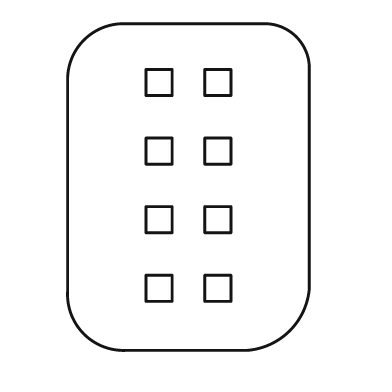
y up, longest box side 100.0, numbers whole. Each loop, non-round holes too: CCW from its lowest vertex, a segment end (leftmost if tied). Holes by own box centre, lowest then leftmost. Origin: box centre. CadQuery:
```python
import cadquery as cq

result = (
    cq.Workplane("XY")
    .moveTo(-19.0, -50.0)
    .lineTo(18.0, -50.0)
    .threePointArc((31.0, -44.0), (37.0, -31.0))
    .lineTo(37.0, 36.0)
    .threePointArc((33.0, 46.0), (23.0, 50.0))
    .lineTo(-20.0, 50.0)
    .threePointArc((-32.0, 45.0), (-37.0, 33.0))
    .lineTo(-37.0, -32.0)
    .threePointArc((-32.0, -45.0), (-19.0, -50.0))
    .close()
    .moveTo(-13.0, -35.0)
    .lineTo(-5.0, -35.0)
    .lineTo(-5.0, -27.0)
    .lineTo(-13.0, -27.0)
    .close()
    .moveTo(5.0, -35.0)
    .lineTo(13.0, -35.0)
    .lineTo(13.0, -27.0)
    .lineTo(5.0, -27.0)
    .close()
    .moveTo(-13.0, -14.0)
    .lineTo(-5.0, -14.0)
    .lineTo(-5.0, -6.0)
    .lineTo(-13.0, -6.0)
    .close()
    .moveTo(5.0, -14.0)
    .lineTo(13.0, -14.0)
    .lineTo(13.0, -6.0)
    .lineTo(5.0, -6.0)
    .close()
    .moveTo(-13.0, 7.0)
    .lineTo(-5.0, 7.0)
    .lineTo(-5.0, 15.0)
    .lineTo(-13.0, 15.0)
    .close()
    .moveTo(5.0, 7.0)
    .lineTo(13.0, 7.0)
    .lineTo(13.0, 15.0)
    .lineTo(5.0, 15.0)
    .close()
    .moveTo(-13.0, 28.0)
    .lineTo(-5.0, 28.0)
    .lineTo(-5.0, 36.0)
    .lineTo(-13.0, 36.0)
    .close()
    .moveTo(5.0, 28.0)
    .lineTo(13.0, 28.0)
    .lineTo(13.0, 36.0)
    .lineTo(5.0, 36.0)
    .close()
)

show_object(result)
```